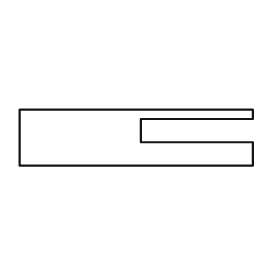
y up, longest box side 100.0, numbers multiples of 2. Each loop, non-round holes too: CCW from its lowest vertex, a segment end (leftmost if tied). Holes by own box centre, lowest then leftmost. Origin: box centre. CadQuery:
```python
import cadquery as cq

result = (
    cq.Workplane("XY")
    .moveTo(-50.0, -12.0)
    .lineTo(50.0, -12.0)
    .lineTo(50.0, -2.0)
    .lineTo(2.0, -2.0)
    .lineTo(2.0, 8.0)
    .lineTo(50.0, 8.0)
    .lineTo(50.0, 12.0)
    .lineTo(-50.0, 12.0)
    .close()
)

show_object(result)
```